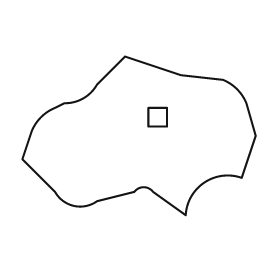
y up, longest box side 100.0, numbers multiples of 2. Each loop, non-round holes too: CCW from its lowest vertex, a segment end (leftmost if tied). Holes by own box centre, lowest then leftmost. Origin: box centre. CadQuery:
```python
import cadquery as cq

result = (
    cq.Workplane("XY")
    .moveTo(20.0, -34.0)
    .threePointArc((28.0, -20.0), (44.0, -18.0))
    .lineTo(50.0, 0.0)
    .lineTo(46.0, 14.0)
    .threePointArc((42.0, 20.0), (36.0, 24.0))
    .lineTo(18.0, 26.0)
    .lineTo(-6.0, 34.0)
    .lineTo(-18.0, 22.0)
    .threePointArc((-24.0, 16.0), (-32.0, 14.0))
    .lineTo(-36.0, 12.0)
    .threePointArc((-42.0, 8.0), (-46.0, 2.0))
    .lineTo(-50.0, -10.0)
    .lineTo(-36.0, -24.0)
    .threePointArc((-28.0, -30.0), (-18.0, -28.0))
    .lineTo(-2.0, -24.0)
    .threePointArc((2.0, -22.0), (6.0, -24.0))
    .close()
    .moveTo(4.0, 4.0)
    .lineTo(12.0, 4.0)
    .lineTo(12.0, 12.0)
    .lineTo(4.0, 12.0)
    .close()
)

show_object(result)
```